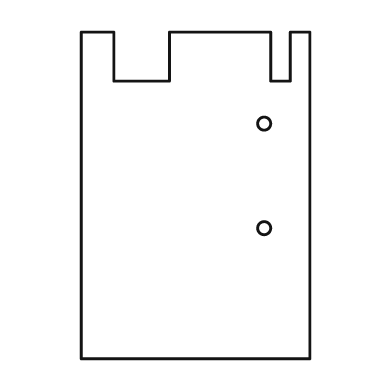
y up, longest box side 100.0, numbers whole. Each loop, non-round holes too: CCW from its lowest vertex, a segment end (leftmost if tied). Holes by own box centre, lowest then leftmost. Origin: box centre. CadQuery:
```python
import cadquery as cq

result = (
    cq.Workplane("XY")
    .moveTo(-35.0, -50.0)
    .lineTo(35.0, -50.0)
    .lineTo(35.0, 50.0)
    .lineTo(29.0, 50.0)
    .lineTo(29.0, 35.0)
    .lineTo(23.0, 35.0)
    .lineTo(23.0, 50.0)
    .lineTo(-8.0, 50.0)
    .lineTo(-8.0, 35.0)
    .lineTo(-25.0, 35.0)
    .lineTo(-25.0, 50.0)
    .lineTo(-35.0, 50.0)
    .close()
    .moveTo(21.0, -10.0)
    .circle(2.0)
    .moveTo(21.0, 22.0)
    .circle(2.0)
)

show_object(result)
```